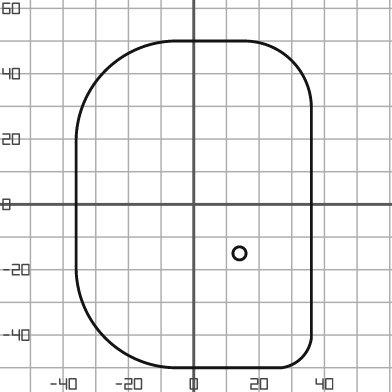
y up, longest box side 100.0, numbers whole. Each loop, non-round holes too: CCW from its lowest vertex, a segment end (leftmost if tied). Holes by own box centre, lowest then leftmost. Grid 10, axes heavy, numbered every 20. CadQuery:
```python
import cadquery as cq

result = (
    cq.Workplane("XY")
    .moveTo(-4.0, -50.0)
    .lineTo(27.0, -50.0)
    .threePointArc((33.0, -47.0), (36.0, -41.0))
    .lineTo(36.0, 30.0)
    .threePointArc((30.0, 44.0), (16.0, 50.0))
    .lineTo(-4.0, 50.0)
    .threePointArc((-27.0, 41.0), (-36.0, 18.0))
    .lineTo(-36.0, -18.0)
    .threePointArc((-27.0, -41.0), (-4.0, -50.0))
    .close()
    .moveTo(14.0, -15.0)
    .circle(2.0)
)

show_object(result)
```